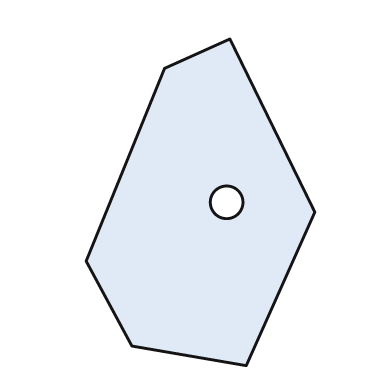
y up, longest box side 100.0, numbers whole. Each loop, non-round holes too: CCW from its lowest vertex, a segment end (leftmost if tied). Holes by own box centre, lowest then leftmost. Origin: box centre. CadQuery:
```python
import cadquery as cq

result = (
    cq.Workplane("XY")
    .moveTo(14.0, -50.0)
    .lineTo(35.0, -3.0)
    .lineTo(9.0, 50.0)
    .lineTo(-11.0, 41.0)
    .lineTo(-35.0, -18.0)
    .lineTo(-21.0, -44.0)
    .close()
    .moveTo(8.0, 0.0)
    .circle(5.0)
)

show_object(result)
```